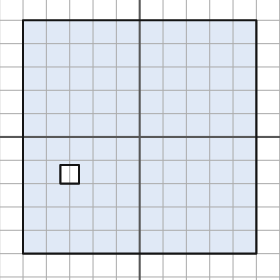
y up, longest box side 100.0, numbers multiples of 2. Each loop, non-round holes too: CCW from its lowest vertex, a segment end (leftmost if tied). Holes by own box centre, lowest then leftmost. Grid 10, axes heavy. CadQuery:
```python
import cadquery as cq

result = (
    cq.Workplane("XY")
    .moveTo(-50.0, -50.0)
    .lineTo(50.0, -50.0)
    .lineTo(50.0, 50.0)
    .lineTo(-50.0, 50.0)
    .close()
    .moveTo(-34.0, -20.0)
    .lineTo(-26.0, -20.0)
    .lineTo(-26.0, -12.0)
    .lineTo(-34.0, -12.0)
    .close()
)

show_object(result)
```